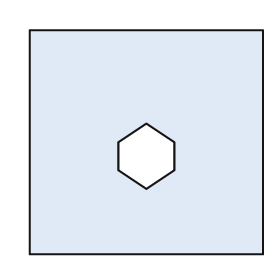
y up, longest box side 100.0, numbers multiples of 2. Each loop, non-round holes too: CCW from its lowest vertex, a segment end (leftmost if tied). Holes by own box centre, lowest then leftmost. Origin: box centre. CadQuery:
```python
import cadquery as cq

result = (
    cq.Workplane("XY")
    .moveTo(-50.0, -48.0)
    .lineTo(50.0, -48.0)
    .lineTo(50.0, 48.0)
    .lineTo(-50.0, 48.0)
    .close()
    .moveTo(0.0, -20.0)
    .lineTo(12.0, -12.0)
    .lineTo(12.0, 0.0)
    .lineTo(0.0, 8.0)
    .lineTo(-12.0, 0.0)
    .lineTo(-12.0, -12.0)
    .close()
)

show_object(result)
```